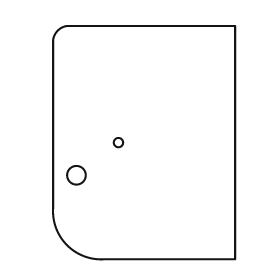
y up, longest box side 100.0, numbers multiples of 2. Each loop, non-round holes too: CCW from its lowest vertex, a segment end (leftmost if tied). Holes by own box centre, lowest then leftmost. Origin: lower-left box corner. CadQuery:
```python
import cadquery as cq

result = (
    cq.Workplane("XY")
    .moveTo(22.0, 0.0)
    .lineTo(78.0, 0.0)
    .lineTo(78.0, 100.0)
    .lineTo(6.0, 100.0)
    .threePointArc((2.0, 98.0), (0.0, 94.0))
    .lineTo(0.0, 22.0)
    .threePointArc((6.0, 6.0), (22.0, 0.0))
    .close()
    .moveTo(10.0, 36.0)
    .circle(4.0)
    .moveTo(28.0, 50.0)
    .circle(2.0)
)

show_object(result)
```